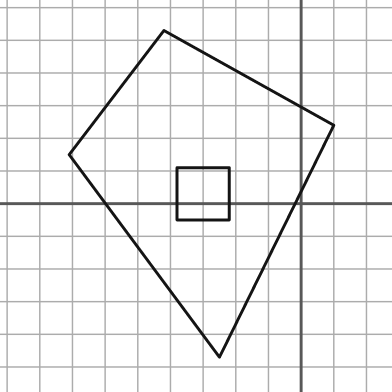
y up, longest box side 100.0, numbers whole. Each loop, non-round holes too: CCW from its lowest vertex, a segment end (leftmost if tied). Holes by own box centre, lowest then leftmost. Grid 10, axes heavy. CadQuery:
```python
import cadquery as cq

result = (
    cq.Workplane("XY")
    .moveTo(-25.0, -47.0)
    .lineTo(10.0, 24.0)
    .lineTo(-42.0, 53.0)
    .lineTo(-71.0, 15.0)
    .close()
    .moveTo(-38.0, -5.0)
    .lineTo(-22.0, -5.0)
    .lineTo(-22.0, 11.0)
    .lineTo(-38.0, 11.0)
    .close()
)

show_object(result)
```